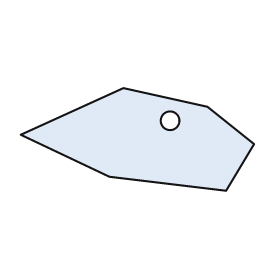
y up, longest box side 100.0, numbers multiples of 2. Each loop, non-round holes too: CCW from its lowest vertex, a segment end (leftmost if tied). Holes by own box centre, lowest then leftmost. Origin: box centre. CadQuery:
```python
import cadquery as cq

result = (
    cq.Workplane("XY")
    .moveTo(38.0, -22.0)
    .lineTo(50.0, -2.0)
    .lineTo(30.0, 14.0)
    .lineTo(-6.0, 22.0)
    .lineTo(-50.0, 2.0)
    .lineTo(-12.0, -16.0)
    .close()
    .moveTo(14.0, 8.0)
    .circle(4.0)
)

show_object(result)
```